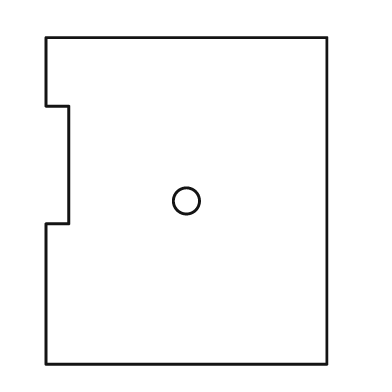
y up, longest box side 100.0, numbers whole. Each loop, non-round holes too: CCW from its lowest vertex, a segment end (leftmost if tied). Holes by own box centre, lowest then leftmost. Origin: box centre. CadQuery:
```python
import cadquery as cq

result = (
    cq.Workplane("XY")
    .moveTo(-43.0, -50.0)
    .lineTo(43.0, -50.0)
    .lineTo(43.0, 50.0)
    .lineTo(-43.0, 50.0)
    .lineTo(-43.0, 29.0)
    .lineTo(-36.0, 29.0)
    .lineTo(-36.0, -7.0)
    .lineTo(-43.0, -7.0)
    .close()
    .moveTo(0.0, 0.0)
    .circle(4.0)
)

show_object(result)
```